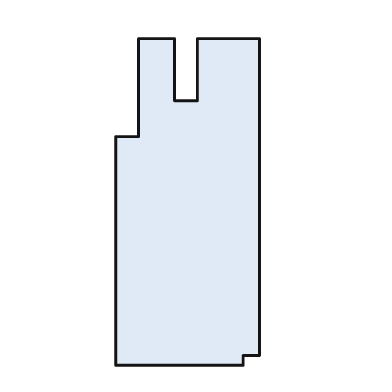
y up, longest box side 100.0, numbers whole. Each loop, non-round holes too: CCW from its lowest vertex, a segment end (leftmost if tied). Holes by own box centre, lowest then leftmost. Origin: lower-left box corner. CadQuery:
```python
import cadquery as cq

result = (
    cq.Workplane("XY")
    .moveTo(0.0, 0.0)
    .lineTo(39.0, 0.0)
    .lineTo(39.0, 3.0)
    .lineTo(44.0, 3.0)
    .lineTo(44.0, 100.0)
    .lineTo(25.0, 100.0)
    .lineTo(25.0, 81.0)
    .lineTo(18.0, 81.0)
    .lineTo(18.0, 100.0)
    .lineTo(7.0, 100.0)
    .lineTo(7.0, 70.0)
    .lineTo(0.0, 70.0)
    .close()
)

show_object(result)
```